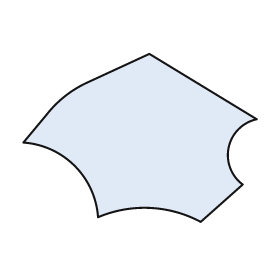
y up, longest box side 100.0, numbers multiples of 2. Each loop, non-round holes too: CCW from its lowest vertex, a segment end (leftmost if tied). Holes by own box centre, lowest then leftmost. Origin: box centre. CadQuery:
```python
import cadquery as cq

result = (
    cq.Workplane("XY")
    .moveTo(26.0, -36.0)
    .lineTo(44.0, -20.0)
    .threePointArc((38.0, -4.0), (50.0, 8.0))
    .lineTo(4.0, 36.0)
    .lineTo(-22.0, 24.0)
    .threePointArc((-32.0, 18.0), (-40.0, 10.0))
    .lineTo(-50.0, -2.0)
    .threePointArc((-28.0, -12.0), (-18.0, -34.0))
    .threePointArc((4.0, -30.0), (26.0, -36.0))
    .close()
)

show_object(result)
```